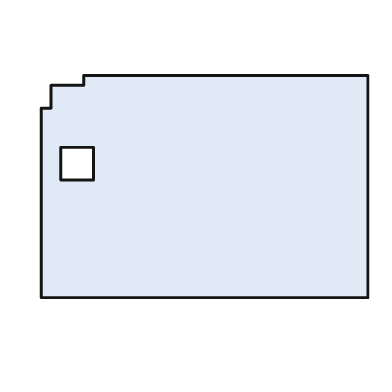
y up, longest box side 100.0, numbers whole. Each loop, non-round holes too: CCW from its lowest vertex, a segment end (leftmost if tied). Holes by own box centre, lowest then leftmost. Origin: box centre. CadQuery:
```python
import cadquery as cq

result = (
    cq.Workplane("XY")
    .moveTo(-50.0, -34.0)
    .lineTo(50.0, -34.0)
    .lineTo(50.0, 34.0)
    .lineTo(-37.0, 34.0)
    .lineTo(-37.0, 31.0)
    .lineTo(-47.0, 31.0)
    .lineTo(-47.0, 24.0)
    .lineTo(-50.0, 24.0)
    .close()
    .moveTo(-44.0, 2.0)
    .lineTo(-34.0, 2.0)
    .lineTo(-34.0, 12.0)
    .lineTo(-44.0, 12.0)
    .close()
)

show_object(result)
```